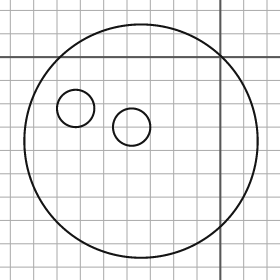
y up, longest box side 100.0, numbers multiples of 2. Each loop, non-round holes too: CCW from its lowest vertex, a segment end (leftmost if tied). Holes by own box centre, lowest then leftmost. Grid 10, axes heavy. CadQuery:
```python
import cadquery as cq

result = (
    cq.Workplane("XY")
    .moveTo(-34.0, -36.0)
    .circle(50.0)
    .moveTo(-38.0, -30.0)
    .circle(8.0)
    .moveTo(-62.0, -22.0)
    .circle(8.0)
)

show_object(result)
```